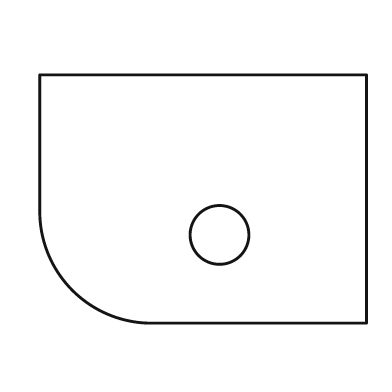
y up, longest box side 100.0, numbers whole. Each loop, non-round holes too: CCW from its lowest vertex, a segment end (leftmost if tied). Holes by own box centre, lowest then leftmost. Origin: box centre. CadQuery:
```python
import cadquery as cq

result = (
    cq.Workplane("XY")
    .moveTo(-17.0, -38.0)
    .lineTo(50.0, -38.0)
    .lineTo(50.0, 38.0)
    .lineTo(-50.0, 38.0)
    .lineTo(-50.0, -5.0)
    .threePointArc((-40.0, -28.0), (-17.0, -38.0))
    .close()
    .moveTo(5.0, -11.0)
    .circle(9.0)
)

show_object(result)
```